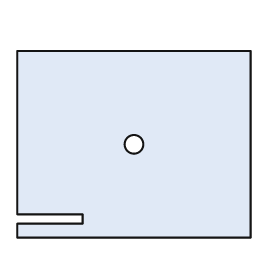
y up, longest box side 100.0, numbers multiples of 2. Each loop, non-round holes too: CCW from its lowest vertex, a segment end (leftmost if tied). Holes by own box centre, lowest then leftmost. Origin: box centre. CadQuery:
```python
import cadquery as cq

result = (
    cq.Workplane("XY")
    .moveTo(-50.0, -40.0)
    .lineTo(50.0, -40.0)
    .lineTo(50.0, 40.0)
    .lineTo(-50.0, 40.0)
    .lineTo(-50.0, -30.0)
    .lineTo(-22.0, -30.0)
    .lineTo(-22.0, -34.0)
    .lineTo(-50.0, -34.0)
    .close()
    .moveTo(0.0, 0.0)
    .circle(4.0)
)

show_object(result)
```